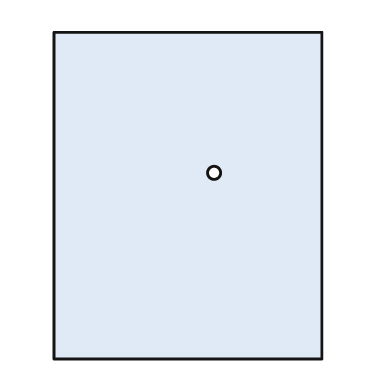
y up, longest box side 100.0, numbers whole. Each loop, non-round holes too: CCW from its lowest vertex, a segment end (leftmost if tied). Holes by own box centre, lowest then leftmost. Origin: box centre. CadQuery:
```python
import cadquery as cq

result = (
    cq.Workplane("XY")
    .moveTo(-41.0, -50.0)
    .lineTo(41.0, -50.0)
    .lineTo(41.0, 50.0)
    .lineTo(-41.0, 50.0)
    .close()
    .moveTo(8.0, 7.0)
    .circle(2.0)
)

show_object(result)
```